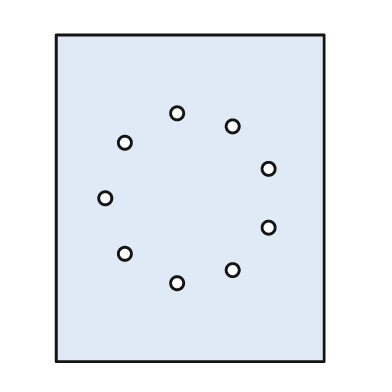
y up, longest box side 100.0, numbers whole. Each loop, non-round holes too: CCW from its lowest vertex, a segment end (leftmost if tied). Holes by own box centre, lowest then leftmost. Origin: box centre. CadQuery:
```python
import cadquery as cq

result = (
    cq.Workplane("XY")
    .moveTo(-41.0, -50.0)
    .lineTo(41.0, -50.0)
    .lineTo(41.0, 50.0)
    .lineTo(-41.0, 50.0)
    .close()
    .moveTo(-4.0, -26.0)
    .circle(2.0)
    .moveTo(13.0, -22.0)
    .circle(2.0)
    .moveTo(-20.0, -17.0)
    .circle(2.0)
    .moveTo(24.0, -9.0)
    .circle(2.0)
    .moveTo(-26.0, 0.0)
    .circle(2.0)
    .moveTo(24.0, 9.0)
    .circle(2.0)
    .moveTo(-20.0, 17.0)
    .circle(2.0)
    .moveTo(13.0, 22.0)
    .circle(2.0)
    .moveTo(-4.0, 26.0)
    .circle(2.0)
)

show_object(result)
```